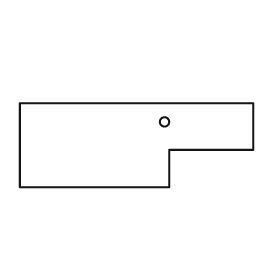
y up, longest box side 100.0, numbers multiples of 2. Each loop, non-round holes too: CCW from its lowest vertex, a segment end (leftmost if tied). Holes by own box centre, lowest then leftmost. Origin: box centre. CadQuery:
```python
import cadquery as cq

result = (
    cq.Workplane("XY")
    .moveTo(-50.0, -18.0)
    .lineTo(14.0, -18.0)
    .lineTo(14.0, -2.0)
    .lineTo(50.0, -2.0)
    .lineTo(50.0, 18.0)
    .lineTo(-50.0, 18.0)
    .close()
    .moveTo(12.0, 10.0)
    .circle(2.0)
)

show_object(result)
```